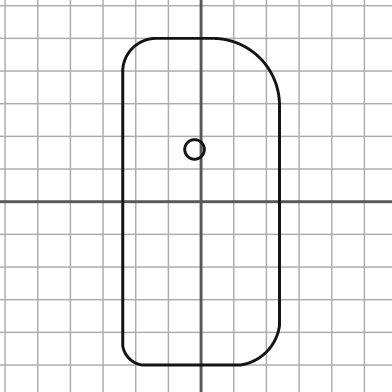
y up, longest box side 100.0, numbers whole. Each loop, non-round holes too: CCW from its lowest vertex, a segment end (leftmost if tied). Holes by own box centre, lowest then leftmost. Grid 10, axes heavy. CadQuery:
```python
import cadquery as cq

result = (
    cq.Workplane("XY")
    .moveTo(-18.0, -50.0)
    .lineTo(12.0, -50.0)
    .threePointArc((20.0, -46.0), (24.0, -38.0))
    .lineTo(24.0, 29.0)
    .threePointArc((18.0, 44.0), (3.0, 50.0))
    .lineTo(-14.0, 50.0)
    .threePointArc((-21.0, 47.0), (-24.0, 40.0))
    .lineTo(-24.0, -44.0)
    .threePointArc((-22.0, -48.0), (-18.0, -50.0))
    .close()
    .moveTo(-2.0, 16.0)
    .circle(3.0)
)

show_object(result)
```